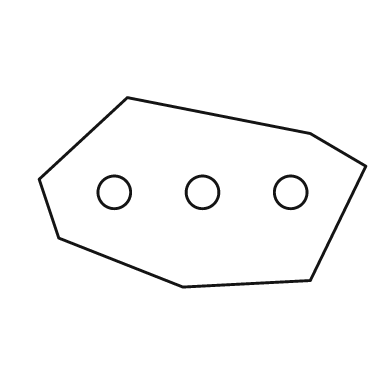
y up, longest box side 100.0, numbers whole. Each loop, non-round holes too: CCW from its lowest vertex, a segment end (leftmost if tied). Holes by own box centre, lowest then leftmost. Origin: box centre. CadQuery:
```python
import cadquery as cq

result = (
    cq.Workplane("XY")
    .moveTo(-6.0, -29.0)
    .lineTo(33.0, -27.0)
    .lineTo(50.0, 8.0)
    .lineTo(33.0, 18.0)
    .lineTo(-23.0, 29.0)
    .lineTo(-50.0, 4.0)
    .lineTo(-44.0, -14.0)
    .close()
    .moveTo(-27.0, 0.0)
    .circle(5.0)
    .moveTo(0.0, 0.0)
    .circle(5.0)
    .moveTo(27.0, 0.0)
    .circle(5.0)
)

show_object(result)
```